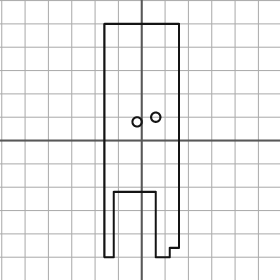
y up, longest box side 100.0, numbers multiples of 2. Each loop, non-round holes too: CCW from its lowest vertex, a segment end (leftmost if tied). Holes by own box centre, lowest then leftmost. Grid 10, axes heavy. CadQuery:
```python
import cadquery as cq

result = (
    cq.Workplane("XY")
    .moveTo(-16.0, -50.0)
    .lineTo(-12.0, -50.0)
    .lineTo(-12.0, -22.0)
    .lineTo(6.0, -22.0)
    .lineTo(6.0, -50.0)
    .lineTo(12.0, -50.0)
    .lineTo(12.0, -46.0)
    .lineTo(16.0, -46.0)
    .lineTo(16.0, 50.0)
    .lineTo(-16.0, 50.0)
    .close()
    .moveTo(-2.0, 8.0)
    .circle(2.0)
    .moveTo(6.0, 10.0)
    .circle(2.0)
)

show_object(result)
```